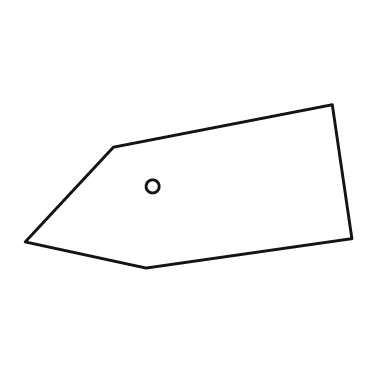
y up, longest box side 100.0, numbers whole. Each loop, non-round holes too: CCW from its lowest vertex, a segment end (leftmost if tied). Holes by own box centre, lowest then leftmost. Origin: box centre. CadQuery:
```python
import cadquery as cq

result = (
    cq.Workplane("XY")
    .moveTo(-13.0, -25.0)
    .lineTo(50.0, -16.0)
    .lineTo(44.0, 25.0)
    .lineTo(-23.0, 12.0)
    .lineTo(-50.0, -17.0)
    .close()
    .moveTo(-11.0, 0.0)
    .circle(2.0)
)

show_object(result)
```